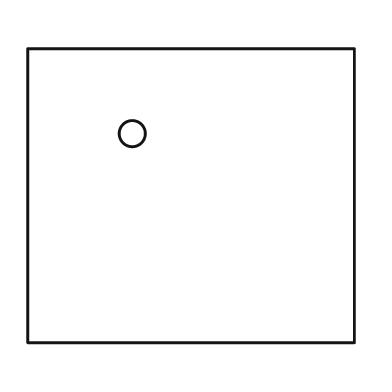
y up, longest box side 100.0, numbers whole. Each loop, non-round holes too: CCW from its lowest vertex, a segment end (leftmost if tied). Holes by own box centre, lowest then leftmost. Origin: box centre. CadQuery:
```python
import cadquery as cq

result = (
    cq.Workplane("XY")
    .moveTo(-50.0, -45.0)
    .lineTo(50.0, -45.0)
    .lineTo(50.0, 45.0)
    .lineTo(-50.0, 45.0)
    .close()
    .moveTo(-18.0, 19.0)
    .circle(4.0)
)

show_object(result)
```